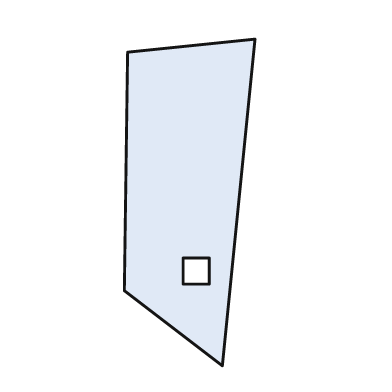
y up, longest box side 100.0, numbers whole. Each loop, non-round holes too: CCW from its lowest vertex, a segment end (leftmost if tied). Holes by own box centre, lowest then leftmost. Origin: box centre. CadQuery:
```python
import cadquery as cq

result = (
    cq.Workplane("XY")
    .moveTo(10.0, -50.0)
    .lineTo(20.0, 50.0)
    .lineTo(-19.0, 46.0)
    .lineTo(-20.0, -27.0)
    .close()
    .moveTo(-2.0, -25.0)
    .lineTo(6.0, -25.0)
    .lineTo(6.0, -17.0)
    .lineTo(-2.0, -17.0)
    .close()
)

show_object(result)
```